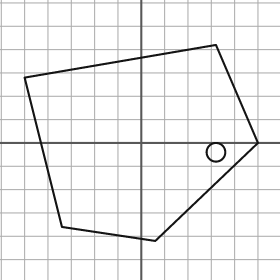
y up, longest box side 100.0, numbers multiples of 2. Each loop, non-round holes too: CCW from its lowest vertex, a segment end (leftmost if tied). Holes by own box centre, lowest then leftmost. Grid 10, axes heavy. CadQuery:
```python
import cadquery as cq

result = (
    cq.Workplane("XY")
    .moveTo(6.0, -42.0)
    .lineTo(50.0, 0.0)
    .lineTo(32.0, 42.0)
    .lineTo(-50.0, 28.0)
    .lineTo(-34.0, -36.0)
    .close()
    .moveTo(32.0, -4.0)
    .circle(4.0)
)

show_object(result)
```